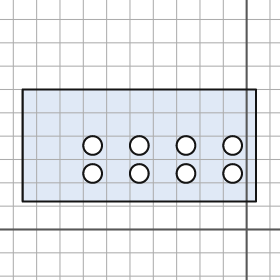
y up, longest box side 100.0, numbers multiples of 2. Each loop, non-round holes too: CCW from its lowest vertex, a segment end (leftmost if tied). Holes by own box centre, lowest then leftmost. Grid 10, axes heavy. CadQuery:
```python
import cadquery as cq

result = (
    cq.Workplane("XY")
    .moveTo(-96.0, 12.0)
    .lineTo(4.0, 12.0)
    .lineTo(4.0, 60.0)
    .lineTo(-96.0, 60.0)
    .close()
    .moveTo(-66.0, 24.0)
    .circle(4.0)
    .moveTo(-46.0, 24.0)
    .circle(4.0)
    .moveTo(-26.0, 24.0)
    .circle(4.0)
    .moveTo(-6.0, 24.0)
    .circle(4.0)
    .moveTo(-66.0, 36.0)
    .circle(4.0)
    .moveTo(-46.0, 36.0)
    .circle(4.0)
    .moveTo(-26.0, 36.0)
    .circle(4.0)
    .moveTo(-6.0, 36.0)
    .circle(4.0)
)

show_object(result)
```